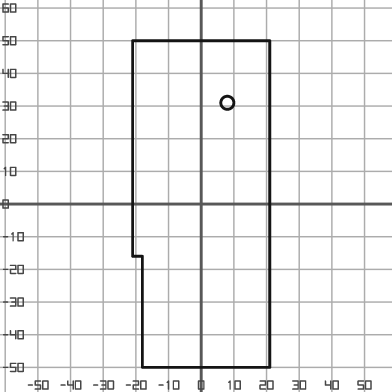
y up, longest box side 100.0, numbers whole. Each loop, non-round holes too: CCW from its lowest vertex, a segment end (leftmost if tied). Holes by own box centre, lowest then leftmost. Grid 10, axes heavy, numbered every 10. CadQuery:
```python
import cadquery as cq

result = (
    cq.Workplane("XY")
    .moveTo(-18.0, -50.0)
    .lineTo(21.0, -50.0)
    .lineTo(21.0, 50.0)
    .lineTo(-21.0, 50.0)
    .lineTo(-21.0, -16.0)
    .lineTo(-18.0, -16.0)
    .close()
    .moveTo(8.0, 31.0)
    .circle(2.0)
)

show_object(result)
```